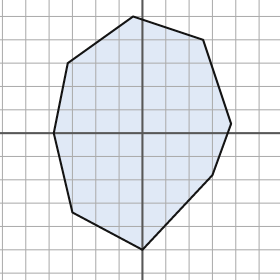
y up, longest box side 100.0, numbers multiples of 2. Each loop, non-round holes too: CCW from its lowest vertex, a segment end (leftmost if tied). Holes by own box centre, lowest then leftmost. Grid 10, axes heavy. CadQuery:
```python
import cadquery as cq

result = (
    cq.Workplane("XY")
    .moveTo(0.0, -50.0)
    .lineTo(30.0, -18.0)
    .lineTo(38.0, 4.0)
    .lineTo(26.0, 40.0)
    .lineTo(-4.0, 50.0)
    .lineTo(-32.0, 30.0)
    .lineTo(-38.0, 0.0)
    .lineTo(-30.0, -34.0)
    .close()
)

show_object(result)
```